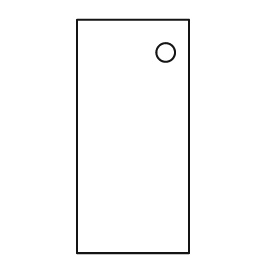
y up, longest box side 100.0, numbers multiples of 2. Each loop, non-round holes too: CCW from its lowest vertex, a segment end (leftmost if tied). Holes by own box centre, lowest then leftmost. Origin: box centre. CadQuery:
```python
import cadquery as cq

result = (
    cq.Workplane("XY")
    .moveTo(-24.0, -50.0)
    .lineTo(24.0, -50.0)
    .lineTo(24.0, 50.0)
    .lineTo(-24.0, 50.0)
    .close()
    .moveTo(14.0, 36.0)
    .circle(4.0)
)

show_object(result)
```